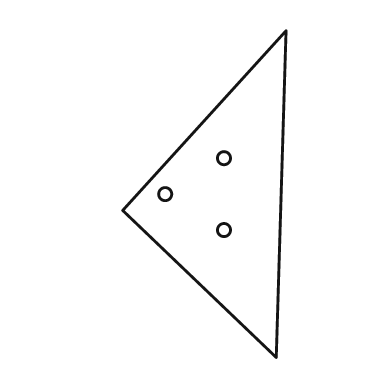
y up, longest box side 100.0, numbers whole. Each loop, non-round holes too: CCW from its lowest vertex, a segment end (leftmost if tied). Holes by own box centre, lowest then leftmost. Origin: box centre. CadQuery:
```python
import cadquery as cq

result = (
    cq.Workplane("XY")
    .moveTo(22.0, -50.0)
    .lineTo(25.0, 50.0)
    .lineTo(-25.0, -5.0)
    .close()
    .moveTo(6.0, -11.0)
    .circle(2.0)
    .moveTo(-12.0, 0.0)
    .circle(2.0)
    .moveTo(6.0, 11.0)
    .circle(2.0)
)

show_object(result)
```